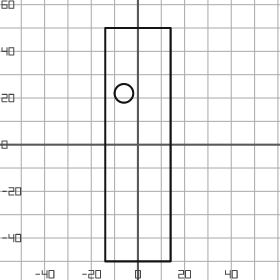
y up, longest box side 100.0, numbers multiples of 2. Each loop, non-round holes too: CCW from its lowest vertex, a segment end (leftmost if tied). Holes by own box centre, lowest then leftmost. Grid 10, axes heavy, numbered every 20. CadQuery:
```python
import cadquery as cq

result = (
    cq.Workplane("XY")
    .moveTo(-14.0, -50.0)
    .lineTo(14.0, -50.0)
    .lineTo(14.0, 50.0)
    .lineTo(-14.0, 50.0)
    .close()
    .moveTo(-6.0, 22.0)
    .circle(4.0)
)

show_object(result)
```